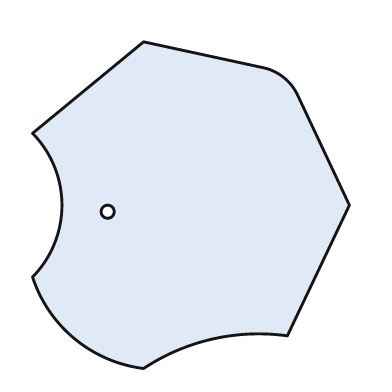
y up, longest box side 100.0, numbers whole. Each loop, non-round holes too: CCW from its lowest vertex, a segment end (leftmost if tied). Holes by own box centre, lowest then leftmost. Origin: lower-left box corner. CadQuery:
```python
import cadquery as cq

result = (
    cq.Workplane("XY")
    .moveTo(34.0, 0.0)
    .threePointArc((55.0, 9.0), (78.0, 10.0))
    .lineTo(97.0, 50.0)
    .lineTo(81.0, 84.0)
    .threePointArc((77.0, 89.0), (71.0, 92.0))
    .lineTo(34.0, 100.0)
    .lineTo(0.0, 72.0)
    .threePointArc((9.0, 50.0), (0.0, 28.0))
    .threePointArc((13.0, 9.0), (34.0, 0.0))
    .close()
    .moveTo(23.0, 48.0)
    .circle(2.0)
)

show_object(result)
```